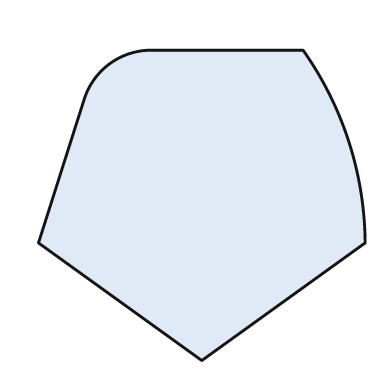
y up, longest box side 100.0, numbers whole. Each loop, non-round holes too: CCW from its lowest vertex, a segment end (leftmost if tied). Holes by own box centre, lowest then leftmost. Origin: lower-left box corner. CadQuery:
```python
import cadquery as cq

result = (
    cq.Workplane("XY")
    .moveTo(50.0, 0.0)
    .lineTo(100.0, 36.0)
    .threePointArc((95.0, 67.0), (81.0, 95.0))
    .lineTo(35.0, 95.0)
    .threePointArc((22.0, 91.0), (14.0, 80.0))
    .lineTo(0.0, 36.0)
    .close()
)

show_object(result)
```